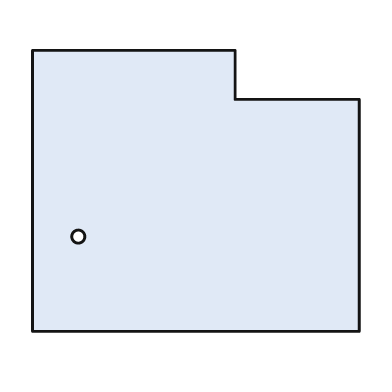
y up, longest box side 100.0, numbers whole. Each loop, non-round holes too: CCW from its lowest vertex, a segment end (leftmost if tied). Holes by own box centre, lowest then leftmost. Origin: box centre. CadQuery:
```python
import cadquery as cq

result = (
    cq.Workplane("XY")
    .moveTo(-50.0, -43.0)
    .lineTo(50.0, -43.0)
    .lineTo(50.0, 28.0)
    .lineTo(12.0, 28.0)
    .lineTo(12.0, 43.0)
    .lineTo(-50.0, 43.0)
    .close()
    .moveTo(-36.0, -14.0)
    .circle(2.0)
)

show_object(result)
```